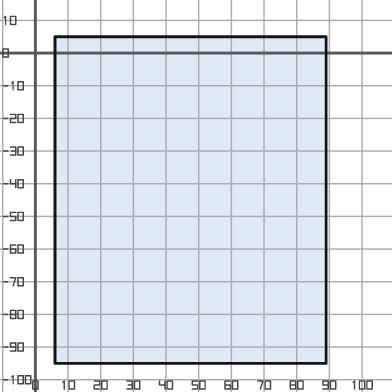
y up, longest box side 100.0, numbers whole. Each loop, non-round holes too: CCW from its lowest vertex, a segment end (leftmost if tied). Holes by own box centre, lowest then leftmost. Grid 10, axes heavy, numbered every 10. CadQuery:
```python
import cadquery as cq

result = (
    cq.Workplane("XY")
    .moveTo(6.0, -95.0)
    .lineTo(89.0, -95.0)
    .lineTo(89.0, 5.0)
    .lineTo(6.0, 5.0)
    .close()
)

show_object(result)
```